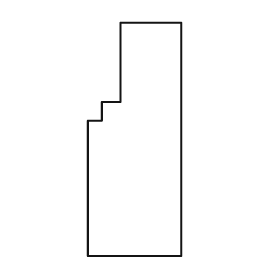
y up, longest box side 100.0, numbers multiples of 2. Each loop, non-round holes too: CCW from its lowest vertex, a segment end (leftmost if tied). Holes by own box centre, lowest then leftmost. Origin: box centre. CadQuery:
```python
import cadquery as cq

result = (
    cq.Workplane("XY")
    .moveTo(-20.0, -50.0)
    .lineTo(20.0, -50.0)
    .lineTo(20.0, 50.0)
    .lineTo(-6.0, 50.0)
    .lineTo(-6.0, 16.0)
    .lineTo(-14.0, 16.0)
    .lineTo(-14.0, 8.0)
    .lineTo(-20.0, 8.0)
    .close()
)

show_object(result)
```